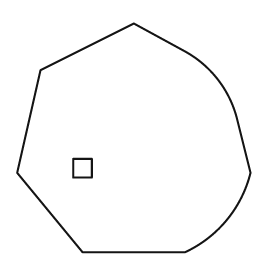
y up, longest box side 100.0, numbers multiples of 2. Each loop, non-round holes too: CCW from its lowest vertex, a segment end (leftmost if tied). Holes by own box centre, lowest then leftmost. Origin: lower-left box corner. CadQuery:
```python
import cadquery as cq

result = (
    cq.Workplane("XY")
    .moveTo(28.0, 0.0)
    .lineTo(72.0, 0.0)
    .threePointArc((90.0, 14.0), (100.0, 34.0))
    .lineTo(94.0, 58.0)
    .threePointArc((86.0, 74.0), (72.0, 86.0))
    .lineTo(50.0, 98.0)
    .lineTo(10.0, 78.0)
    .lineTo(0.0, 34.0)
    .close()
    .moveTo(24.0, 32.0)
    .lineTo(32.0, 32.0)
    .lineTo(32.0, 40.0)
    .lineTo(24.0, 40.0)
    .close()
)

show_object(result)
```